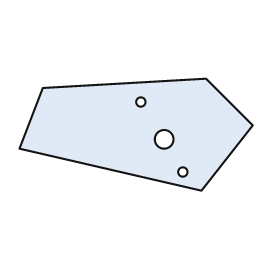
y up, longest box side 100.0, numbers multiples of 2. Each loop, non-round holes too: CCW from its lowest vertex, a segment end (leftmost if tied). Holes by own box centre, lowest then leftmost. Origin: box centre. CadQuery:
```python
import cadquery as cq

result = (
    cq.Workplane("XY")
    .moveTo(28.0, -24.0)
    .lineTo(50.0, 4.0)
    .lineTo(30.0, 24.0)
    .lineTo(-40.0, 20.0)
    .lineTo(-50.0, -6.0)
    .close()
    .moveTo(20.0, -16.0)
    .circle(2.0)
    .moveTo(12.0, -2.0)
    .circle(4.0)
    .moveTo(2.0, 14.0)
    .circle(2.0)
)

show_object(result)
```